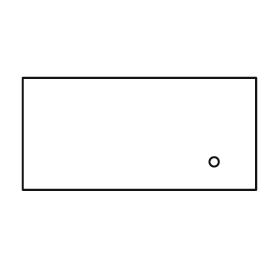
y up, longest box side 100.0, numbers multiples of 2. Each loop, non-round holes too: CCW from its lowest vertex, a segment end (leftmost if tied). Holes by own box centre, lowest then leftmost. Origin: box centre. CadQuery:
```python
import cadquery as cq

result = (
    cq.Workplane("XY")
    .moveTo(-50.0, -24.0)
    .lineTo(50.0, -24.0)
    .lineTo(50.0, 24.0)
    .lineTo(-50.0, 24.0)
    .close()
    .moveTo(32.0, -12.0)
    .circle(2.0)
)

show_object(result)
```